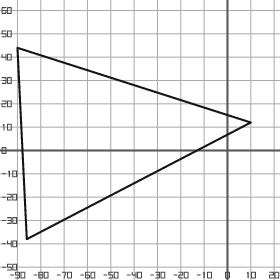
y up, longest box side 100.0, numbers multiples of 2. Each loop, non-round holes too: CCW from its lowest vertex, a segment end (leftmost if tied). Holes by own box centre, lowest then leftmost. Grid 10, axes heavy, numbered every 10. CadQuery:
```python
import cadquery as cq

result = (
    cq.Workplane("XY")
    .moveTo(-86.0, -38.0)
    .lineTo(10.0, 12.0)
    .lineTo(-90.0, 44.0)
    .close()
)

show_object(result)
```